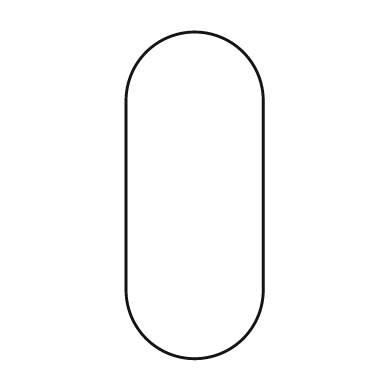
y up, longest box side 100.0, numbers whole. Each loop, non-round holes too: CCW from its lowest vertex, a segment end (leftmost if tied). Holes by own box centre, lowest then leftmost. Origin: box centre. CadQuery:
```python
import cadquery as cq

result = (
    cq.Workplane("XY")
    .moveTo(-21.0, -29.0)
    .threePointArc((0.0, -50.0), (21.0, -29.0))
    .lineTo(21.0, 29.0)
    .threePointArc((0.0, 50.0), (-21.0, 29.0))
    .close()
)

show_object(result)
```